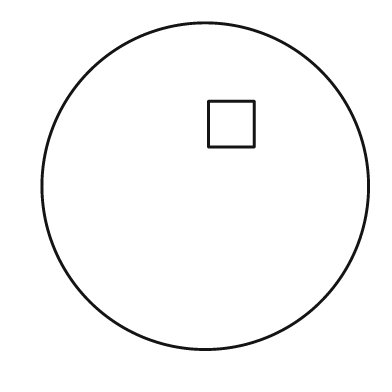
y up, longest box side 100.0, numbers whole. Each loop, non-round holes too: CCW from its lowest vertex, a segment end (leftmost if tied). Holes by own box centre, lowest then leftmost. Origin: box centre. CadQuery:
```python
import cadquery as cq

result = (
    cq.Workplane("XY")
    .moveTo(0.0, 0.0)
    .circle(50.0)
    .moveTo(1.0, 12.0)
    .lineTo(15.0, 12.0)
    .lineTo(15.0, 26.0)
    .lineTo(1.0, 26.0)
    .close()
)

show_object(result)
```